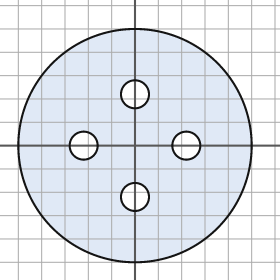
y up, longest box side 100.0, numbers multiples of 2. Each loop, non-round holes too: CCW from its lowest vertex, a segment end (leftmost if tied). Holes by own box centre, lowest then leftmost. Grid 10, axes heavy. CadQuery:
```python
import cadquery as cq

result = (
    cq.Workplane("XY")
    .moveTo(0.0, 0.0)
    .circle(50.0)
    .moveTo(0.0, -22.0)
    .circle(6.0)
    .moveTo(-22.0, 0.0)
    .circle(6.0)
    .moveTo(22.0, 0.0)
    .circle(6.0)
    .moveTo(0.0, 22.0)
    .circle(6.0)
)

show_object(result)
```